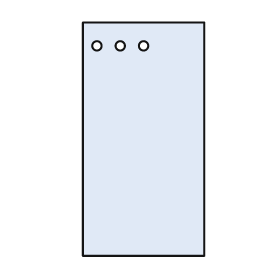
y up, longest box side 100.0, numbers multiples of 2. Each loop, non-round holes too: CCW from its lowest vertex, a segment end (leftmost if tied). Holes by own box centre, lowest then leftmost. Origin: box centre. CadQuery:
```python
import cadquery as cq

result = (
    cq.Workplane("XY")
    .moveTo(-26.0, -50.0)
    .lineTo(26.0, -50.0)
    .lineTo(26.0, 50.0)
    .lineTo(-26.0, 50.0)
    .close()
    .moveTo(-20.0, 40.0)
    .circle(2.0)
    .moveTo(-10.0, 40.0)
    .circle(2.0)
    .moveTo(0.0, 40.0)
    .circle(2.0)
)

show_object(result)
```